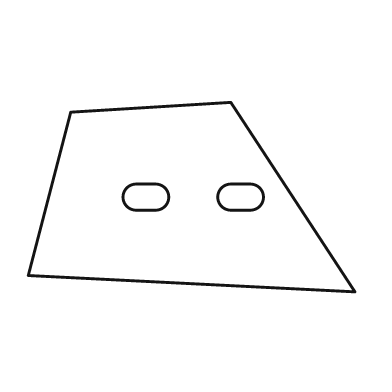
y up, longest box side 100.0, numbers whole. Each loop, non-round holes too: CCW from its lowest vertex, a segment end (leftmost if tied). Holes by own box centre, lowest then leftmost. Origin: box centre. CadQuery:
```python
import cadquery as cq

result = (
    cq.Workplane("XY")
    .moveTo(50.0, -29.0)
    .lineTo(12.0, 29.0)
    .lineTo(-37.0, 26.0)
    .lineTo(-50.0, -24.0)
    .close()
    .moveTo(-17.0, -4.0)
    .lineTo(-11.0, -4.0)
    .threePointArc((-7.0, 0.0), (-11.0, 4.0))
    .lineTo(-17.0, 4.0)
    .threePointArc((-21.0, 0.0), (-17.0, -4.0))
    .close()
    .moveTo(12.0, -4.0)
    .lineTo(18.0, -4.0)
    .threePointArc((22.0, 0.0), (18.0, 4.0))
    .lineTo(12.0, 4.0)
    .threePointArc((8.0, 0.0), (12.0, -4.0))
    .close()
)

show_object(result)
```